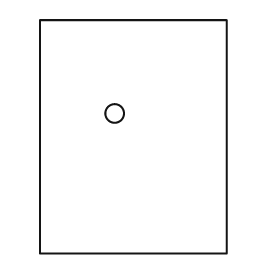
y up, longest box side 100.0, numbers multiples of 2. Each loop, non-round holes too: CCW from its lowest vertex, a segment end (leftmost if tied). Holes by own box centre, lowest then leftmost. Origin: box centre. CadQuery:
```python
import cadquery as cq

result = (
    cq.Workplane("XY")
    .moveTo(-40.0, -50.0)
    .lineTo(40.0, -50.0)
    .lineTo(40.0, 50.0)
    .lineTo(-40.0, 50.0)
    .close()
    .moveTo(-8.0, 10.0)
    .circle(4.0)
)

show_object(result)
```